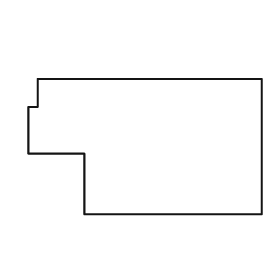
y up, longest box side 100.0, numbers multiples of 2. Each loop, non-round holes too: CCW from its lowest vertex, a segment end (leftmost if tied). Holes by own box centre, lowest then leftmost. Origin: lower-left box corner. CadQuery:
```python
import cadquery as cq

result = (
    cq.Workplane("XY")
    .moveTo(24.0, 0.0)
    .lineTo(100.0, 0.0)
    .lineTo(100.0, 58.0)
    .lineTo(4.0, 58.0)
    .lineTo(4.0, 46.0)
    .lineTo(0.0, 46.0)
    .lineTo(0.0, 26.0)
    .lineTo(24.0, 26.0)
    .close()
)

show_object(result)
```